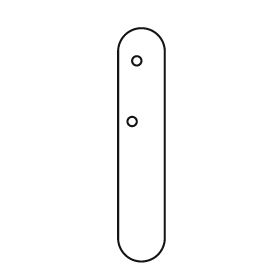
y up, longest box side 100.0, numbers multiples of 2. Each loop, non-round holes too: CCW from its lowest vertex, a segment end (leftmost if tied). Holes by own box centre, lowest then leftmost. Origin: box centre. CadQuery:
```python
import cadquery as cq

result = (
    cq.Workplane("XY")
    .moveTo(-10.0, -40.0)
    .threePointArc((0.0, -50.0), (10.0, -40.0))
    .lineTo(10.0, 40.0)
    .threePointArc((0.0, 50.0), (-10.0, 40.0))
    .close()
    .moveTo(-4.0, 10.0)
    .circle(2.0)
    .moveTo(-2.0, 36.0)
    .circle(2.0)
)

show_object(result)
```